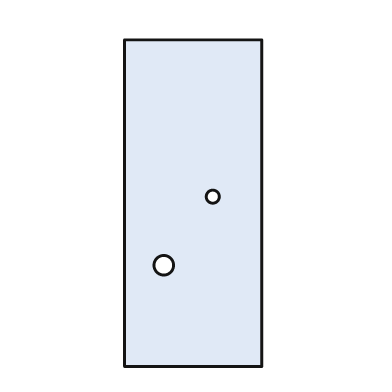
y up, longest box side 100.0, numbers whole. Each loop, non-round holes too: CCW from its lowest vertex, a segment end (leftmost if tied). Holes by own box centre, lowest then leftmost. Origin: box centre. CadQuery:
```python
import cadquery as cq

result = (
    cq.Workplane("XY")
    .moveTo(-21.0, -50.0)
    .lineTo(21.0, -50.0)
    .lineTo(21.0, 50.0)
    .lineTo(-21.0, 50.0)
    .close()
    .moveTo(-9.0, -19.0)
    .circle(3.0)
    .moveTo(6.0, 2.0)
    .circle(2.0)
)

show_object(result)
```